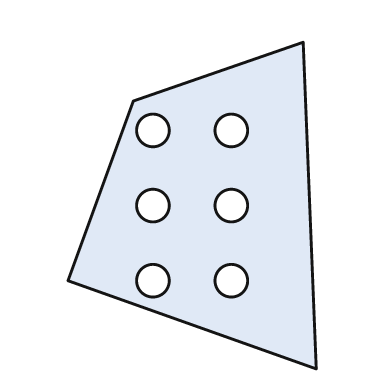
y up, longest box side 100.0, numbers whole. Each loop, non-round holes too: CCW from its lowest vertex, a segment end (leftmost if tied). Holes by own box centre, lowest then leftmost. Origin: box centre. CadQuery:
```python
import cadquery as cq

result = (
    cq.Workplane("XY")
    .moveTo(38.0, -50.0)
    .lineTo(34.0, 50.0)
    .lineTo(-18.0, 32.0)
    .lineTo(-38.0, -23.0)
    .close()
    .moveTo(-12.0, -23.0)
    .circle(5.0)
    .moveTo(12.0, -23.0)
    .circle(5.0)
    .moveTo(-12.0, 0.0)
    .circle(5.0)
    .moveTo(12.0, 0.0)
    .circle(5.0)
    .moveTo(-12.0, 23.0)
    .circle(5.0)
    .moveTo(12.0, 23.0)
    .circle(5.0)
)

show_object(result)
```